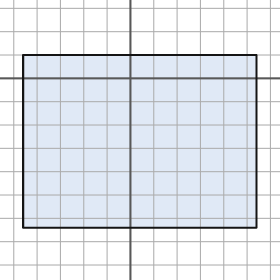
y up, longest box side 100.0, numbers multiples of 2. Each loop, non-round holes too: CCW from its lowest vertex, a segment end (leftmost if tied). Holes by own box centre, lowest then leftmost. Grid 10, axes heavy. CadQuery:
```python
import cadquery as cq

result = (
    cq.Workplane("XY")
    .moveTo(-46.0, -64.0)
    .lineTo(54.0, -64.0)
    .lineTo(54.0, 10.0)
    .lineTo(-46.0, 10.0)
    .close()
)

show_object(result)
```